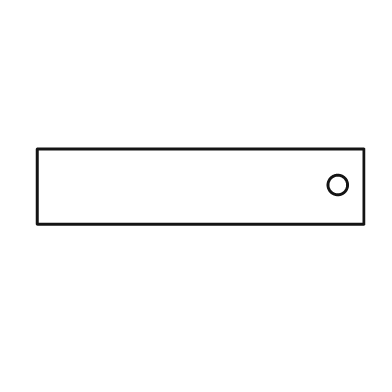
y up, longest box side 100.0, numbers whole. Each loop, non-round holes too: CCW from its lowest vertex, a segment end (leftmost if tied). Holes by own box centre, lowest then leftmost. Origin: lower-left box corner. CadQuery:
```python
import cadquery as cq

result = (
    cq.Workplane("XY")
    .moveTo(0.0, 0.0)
    .lineTo(100.0, 0.0)
    .lineTo(100.0, 23.0)
    .lineTo(0.0, 23.0)
    .close()
    .moveTo(92.0, 12.0)
    .circle(3.0)
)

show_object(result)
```